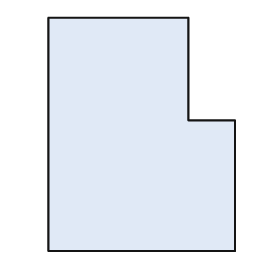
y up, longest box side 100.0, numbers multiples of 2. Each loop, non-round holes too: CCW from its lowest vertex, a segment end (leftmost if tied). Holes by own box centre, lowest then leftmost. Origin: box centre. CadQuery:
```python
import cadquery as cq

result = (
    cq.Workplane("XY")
    .moveTo(-40.0, -50.0)
    .lineTo(40.0, -50.0)
    .lineTo(40.0, 6.0)
    .lineTo(20.0, 6.0)
    .lineTo(20.0, 50.0)
    .lineTo(-40.0, 50.0)
    .close()
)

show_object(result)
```